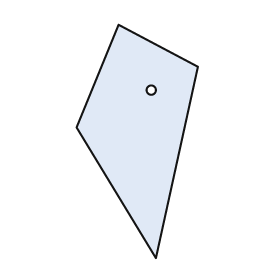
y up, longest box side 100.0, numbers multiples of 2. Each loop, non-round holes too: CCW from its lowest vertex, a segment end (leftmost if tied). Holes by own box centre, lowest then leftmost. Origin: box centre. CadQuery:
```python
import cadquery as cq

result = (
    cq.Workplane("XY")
    .moveTo(8.0, -50.0)
    .lineTo(26.0, 32.0)
    .lineTo(-8.0, 50.0)
    .lineTo(-26.0, 6.0)
    .close()
    .moveTo(6.0, 22.0)
    .circle(2.0)
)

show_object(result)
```